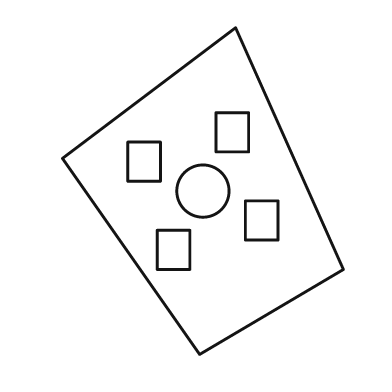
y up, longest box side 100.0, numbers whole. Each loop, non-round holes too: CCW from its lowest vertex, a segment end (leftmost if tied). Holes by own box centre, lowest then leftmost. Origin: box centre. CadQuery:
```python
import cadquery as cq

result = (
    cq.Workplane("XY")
    .moveTo(-1.0, -50.0)
    .lineTo(43.0, -24.0)
    .lineTo(10.0, 50.0)
    .lineTo(-43.0, 10.0)
    .close()
    .moveTo(-14.0, -24.0)
    .lineTo(-4.0, -24.0)
    .lineTo(-4.0, -12.0)
    .lineTo(-14.0, -12.0)
    .close()
    .moveTo(13.0, -15.0)
    .lineTo(23.0, -15.0)
    .lineTo(23.0, -3.0)
    .lineTo(13.0, -3.0)
    .close()
    .moveTo(0.0, 0.0)
    .circle(8.0)
    .moveTo(-23.0, 3.0)
    .lineTo(-13.0, 3.0)
    .lineTo(-13.0, 15.0)
    .lineTo(-23.0, 15.0)
    .close()
    .moveTo(4.0, 12.0)
    .lineTo(14.0, 12.0)
    .lineTo(14.0, 24.0)
    .lineTo(4.0, 24.0)
    .close()
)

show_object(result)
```